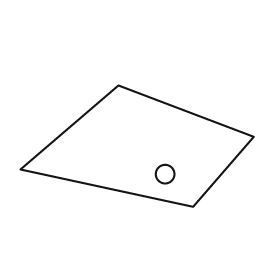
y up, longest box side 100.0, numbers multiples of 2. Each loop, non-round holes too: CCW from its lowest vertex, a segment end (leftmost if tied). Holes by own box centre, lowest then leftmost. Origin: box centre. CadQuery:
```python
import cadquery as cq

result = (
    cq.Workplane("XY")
    .moveTo(24.0, -26.0)
    .lineTo(50.0, 4.0)
    .lineTo(-8.0, 26.0)
    .lineTo(-50.0, -10.0)
    .close()
    .moveTo(12.0, -12.0)
    .circle(4.0)
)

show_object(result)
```